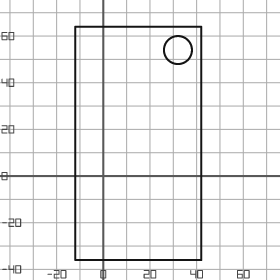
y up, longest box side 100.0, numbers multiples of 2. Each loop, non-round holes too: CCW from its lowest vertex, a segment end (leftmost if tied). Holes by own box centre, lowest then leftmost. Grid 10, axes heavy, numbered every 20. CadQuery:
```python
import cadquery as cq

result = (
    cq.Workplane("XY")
    .moveTo(-12.0, -36.0)
    .lineTo(42.0, -36.0)
    .lineTo(42.0, 64.0)
    .lineTo(-12.0, 64.0)
    .close()
    .moveTo(32.0, 54.0)
    .circle(6.0)
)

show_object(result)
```